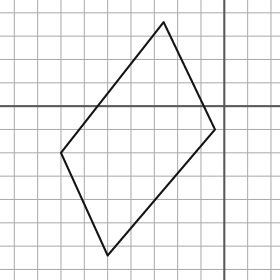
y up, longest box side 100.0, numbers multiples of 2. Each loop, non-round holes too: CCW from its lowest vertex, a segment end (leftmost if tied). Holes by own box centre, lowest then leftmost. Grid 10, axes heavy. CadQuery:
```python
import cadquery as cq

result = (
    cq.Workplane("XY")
    .moveTo(-50.0, -64.0)
    .lineTo(-4.0, -10.0)
    .lineTo(-26.0, 36.0)
    .lineTo(-70.0, -20.0)
    .close()
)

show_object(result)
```